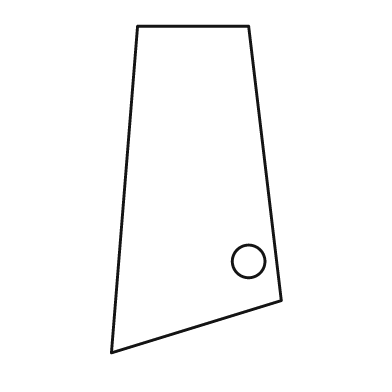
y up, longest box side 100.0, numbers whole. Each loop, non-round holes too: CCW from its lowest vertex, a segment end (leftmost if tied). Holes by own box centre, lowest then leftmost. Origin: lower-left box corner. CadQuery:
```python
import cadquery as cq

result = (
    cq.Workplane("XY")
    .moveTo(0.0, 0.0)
    .lineTo(52.0, 16.0)
    .lineTo(42.0, 100.0)
    .lineTo(8.0, 100.0)
    .close()
    .moveTo(42.0, 28.0)
    .circle(5.0)
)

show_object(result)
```